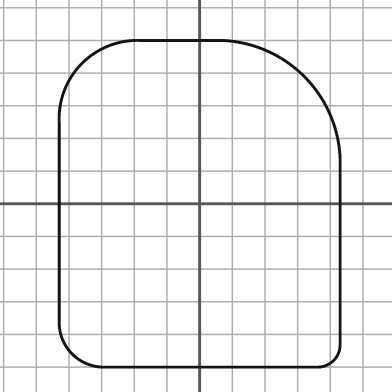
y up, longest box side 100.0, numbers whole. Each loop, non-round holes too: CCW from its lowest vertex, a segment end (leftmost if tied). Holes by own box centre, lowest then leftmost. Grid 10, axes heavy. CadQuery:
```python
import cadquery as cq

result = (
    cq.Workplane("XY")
    .moveTo(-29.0, -50.0)
    .lineTo(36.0, -50.0)
    .threePointArc((41.0, -48.0), (43.0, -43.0))
    .lineTo(43.0, 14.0)
    .threePointArc((32.0, 39.0), (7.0, 50.0))
    .lineTo(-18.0, 50.0)
    .threePointArc((-36.0, 43.0), (-43.0, 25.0))
    .lineTo(-43.0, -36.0)
    .threePointArc((-39.0, -46.0), (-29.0, -50.0))
    .close()
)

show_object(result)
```